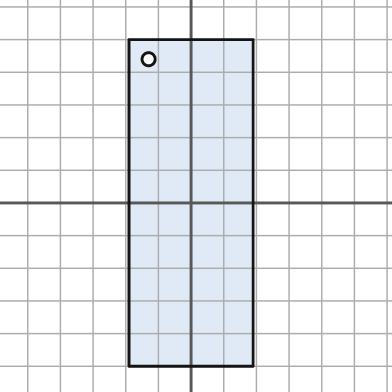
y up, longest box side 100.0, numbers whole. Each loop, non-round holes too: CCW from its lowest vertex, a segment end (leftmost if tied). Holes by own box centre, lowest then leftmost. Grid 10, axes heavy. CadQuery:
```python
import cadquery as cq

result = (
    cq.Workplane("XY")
    .moveTo(-19.0, -50.0)
    .lineTo(19.0, -50.0)
    .lineTo(19.0, 50.0)
    .lineTo(-19.0, 50.0)
    .close()
    .moveTo(-13.0, 44.0)
    .circle(2.0)
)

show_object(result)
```